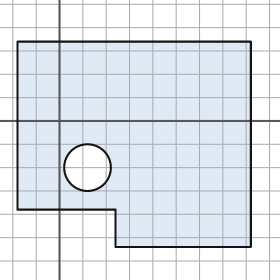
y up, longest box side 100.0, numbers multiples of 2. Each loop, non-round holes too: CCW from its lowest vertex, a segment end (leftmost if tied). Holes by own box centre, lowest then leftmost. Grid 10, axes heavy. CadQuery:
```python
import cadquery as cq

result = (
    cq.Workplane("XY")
    .moveTo(24.0, -54.0)
    .lineTo(82.0, -54.0)
    .lineTo(82.0, 34.0)
    .lineTo(-18.0, 34.0)
    .lineTo(-18.0, -38.0)
    .lineTo(24.0, -38.0)
    .close()
    .moveTo(12.0, -20.0)
    .circle(10.0)
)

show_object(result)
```